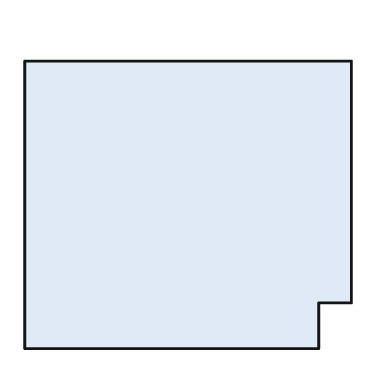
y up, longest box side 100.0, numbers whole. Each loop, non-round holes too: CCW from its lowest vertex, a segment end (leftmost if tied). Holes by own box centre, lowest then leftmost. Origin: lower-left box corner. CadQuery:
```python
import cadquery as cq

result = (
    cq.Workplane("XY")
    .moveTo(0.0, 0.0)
    .lineTo(90.0, 0.0)
    .lineTo(90.0, 14.0)
    .lineTo(100.0, 14.0)
    .lineTo(100.0, 88.0)
    .lineTo(0.0, 88.0)
    .close()
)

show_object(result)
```